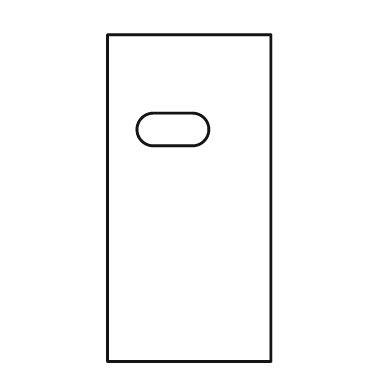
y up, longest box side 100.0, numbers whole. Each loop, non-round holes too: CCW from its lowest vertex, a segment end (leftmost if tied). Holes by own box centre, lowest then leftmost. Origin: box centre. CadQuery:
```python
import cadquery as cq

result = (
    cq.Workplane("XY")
    .moveTo(-25.0, -50.0)
    .lineTo(25.0, -50.0)
    .lineTo(25.0, 50.0)
    .lineTo(-25.0, 50.0)
    .close()
    .moveTo(-11.0, 16.0)
    .lineTo(1.0, 16.0)
    .threePointArc((6.0, 21.0), (1.0, 26.0))
    .lineTo(-11.0, 26.0)
    .threePointArc((-16.0, 21.0), (-11.0, 16.0))
    .close()
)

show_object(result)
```